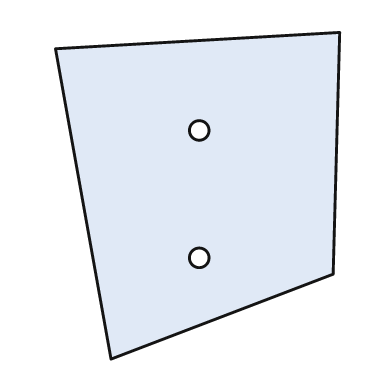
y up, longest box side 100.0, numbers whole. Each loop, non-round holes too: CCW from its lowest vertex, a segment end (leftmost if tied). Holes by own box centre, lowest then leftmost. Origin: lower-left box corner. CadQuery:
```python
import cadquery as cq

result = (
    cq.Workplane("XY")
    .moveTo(17.0, 0.0)
    .lineTo(85.0, 26.0)
    .lineTo(87.0, 100.0)
    .lineTo(0.0, 95.0)
    .close()
    .moveTo(44.0, 31.0)
    .circle(3.0)
    .moveTo(44.0, 70.0)
    .circle(3.0)
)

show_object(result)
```